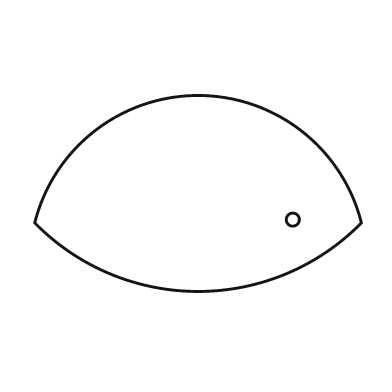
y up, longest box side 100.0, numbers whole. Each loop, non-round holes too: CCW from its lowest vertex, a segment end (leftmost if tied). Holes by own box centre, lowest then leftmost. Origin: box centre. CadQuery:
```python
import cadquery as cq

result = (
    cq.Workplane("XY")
    .moveTo(-50.0, -9.0)
    .threePointArc((0.0, -30.0), (50.0, -9.0))
    .threePointArc((0.0, 30.0), (-50.0, -9.0))
    .close()
    .moveTo(29.0, -8.0)
    .circle(2.0)
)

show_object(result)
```